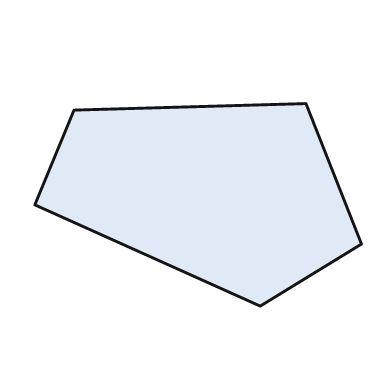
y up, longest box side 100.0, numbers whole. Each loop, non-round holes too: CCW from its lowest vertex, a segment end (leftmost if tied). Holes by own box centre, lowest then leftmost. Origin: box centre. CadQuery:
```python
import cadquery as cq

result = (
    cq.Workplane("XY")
    .moveTo(19.0, -31.0)
    .lineTo(50.0, -12.0)
    .lineTo(33.0, 31.0)
    .lineTo(-38.0, 29.0)
    .lineTo(-50.0, 0.0)
    .close()
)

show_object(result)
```